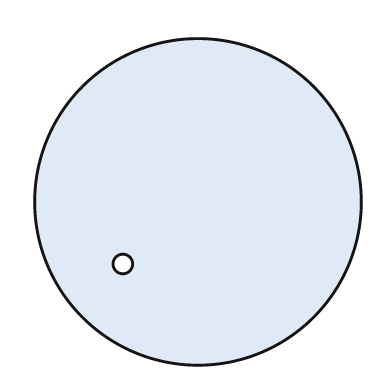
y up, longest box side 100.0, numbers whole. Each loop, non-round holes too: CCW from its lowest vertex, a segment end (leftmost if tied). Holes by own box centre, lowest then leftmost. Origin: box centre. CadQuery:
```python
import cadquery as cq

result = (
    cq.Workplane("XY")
    .moveTo(0.0, 0.0)
    .circle(50.0)
    .moveTo(-23.0, -19.0)
    .circle(3.0)
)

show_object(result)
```